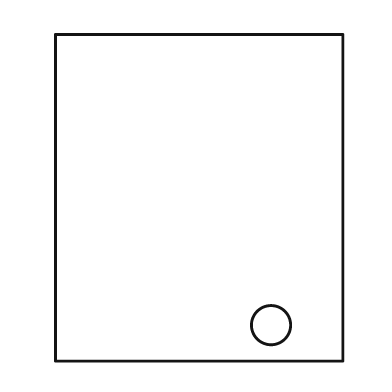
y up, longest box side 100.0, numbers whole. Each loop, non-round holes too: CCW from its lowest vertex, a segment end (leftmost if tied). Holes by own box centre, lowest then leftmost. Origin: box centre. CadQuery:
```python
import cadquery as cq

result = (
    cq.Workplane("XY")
    .moveTo(-44.0, -50.0)
    .lineTo(44.0, -50.0)
    .lineTo(44.0, 50.0)
    .lineTo(-44.0, 50.0)
    .close()
    .moveTo(22.0, -39.0)
    .circle(6.0)
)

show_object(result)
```